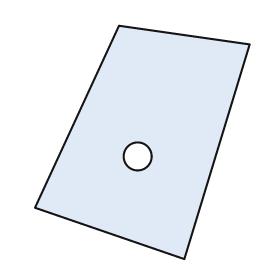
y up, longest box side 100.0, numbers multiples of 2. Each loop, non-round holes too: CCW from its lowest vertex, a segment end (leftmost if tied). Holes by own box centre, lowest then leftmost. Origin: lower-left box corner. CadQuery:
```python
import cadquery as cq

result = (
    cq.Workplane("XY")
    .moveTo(64.0, 0.0)
    .lineTo(92.0, 92.0)
    .lineTo(36.0, 100.0)
    .lineTo(0.0, 22.0)
    .close()
    .moveTo(44.0, 44.0)
    .circle(6.0)
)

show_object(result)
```